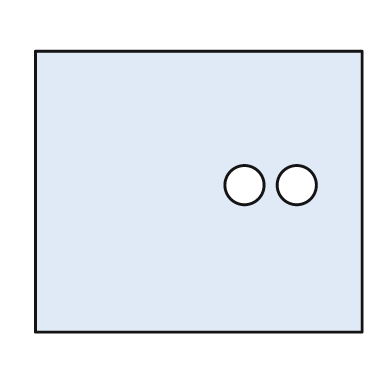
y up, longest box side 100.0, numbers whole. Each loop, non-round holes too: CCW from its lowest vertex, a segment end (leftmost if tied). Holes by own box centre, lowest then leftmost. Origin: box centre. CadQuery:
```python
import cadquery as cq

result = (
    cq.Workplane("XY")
    .moveTo(-50.0, -43.0)
    .lineTo(50.0, -43.0)
    .lineTo(50.0, 43.0)
    .lineTo(-50.0, 43.0)
    .close()
    .moveTo(14.0, 2.0)
    .circle(6.0)
    .moveTo(30.0, 2.0)
    .circle(6.0)
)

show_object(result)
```